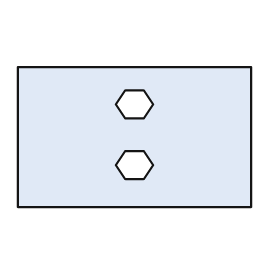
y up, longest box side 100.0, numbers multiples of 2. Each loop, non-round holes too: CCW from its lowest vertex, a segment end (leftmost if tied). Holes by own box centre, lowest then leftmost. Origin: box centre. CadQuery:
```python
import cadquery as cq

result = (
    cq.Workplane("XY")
    .moveTo(-50.0, -30.0)
    .lineTo(50.0, -30.0)
    .lineTo(50.0, 30.0)
    .lineTo(-50.0, 30.0)
    .close()
    .moveTo(-4.0, -18.0)
    .lineTo(4.0, -18.0)
    .lineTo(8.0, -12.0)
    .lineTo(4.0, -6.0)
    .lineTo(-4.0, -6.0)
    .lineTo(-8.0, -12.0)
    .close()
    .moveTo(-4.0, 8.0)
    .lineTo(4.0, 8.0)
    .lineTo(8.0, 14.0)
    .lineTo(4.0, 20.0)
    .lineTo(-4.0, 20.0)
    .lineTo(-8.0, 14.0)
    .close()
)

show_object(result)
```